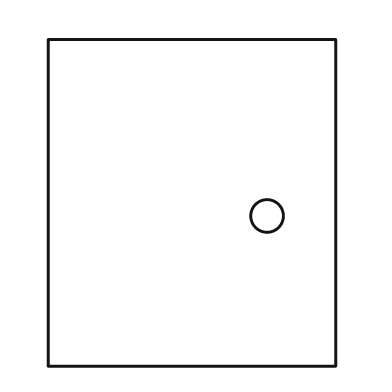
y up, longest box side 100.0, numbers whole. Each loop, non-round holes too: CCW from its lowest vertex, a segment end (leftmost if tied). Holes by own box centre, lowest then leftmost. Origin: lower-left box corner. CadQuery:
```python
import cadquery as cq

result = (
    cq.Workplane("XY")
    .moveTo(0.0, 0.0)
    .lineTo(88.0, 0.0)
    .lineTo(88.0, 100.0)
    .lineTo(0.0, 100.0)
    .close()
    .moveTo(67.0, 46.0)
    .circle(5.0)
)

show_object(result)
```